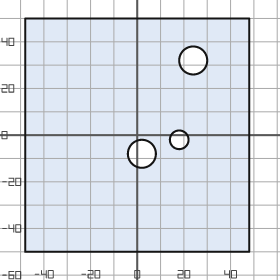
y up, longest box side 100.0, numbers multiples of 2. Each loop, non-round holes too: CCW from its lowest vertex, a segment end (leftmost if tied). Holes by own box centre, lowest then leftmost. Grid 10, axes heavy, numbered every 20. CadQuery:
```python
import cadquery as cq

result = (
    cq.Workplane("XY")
    .moveTo(-48.0, -50.0)
    .lineTo(48.0, -50.0)
    .lineTo(48.0, 50.0)
    .lineTo(-48.0, 50.0)
    .close()
    .moveTo(2.0, -8.0)
    .circle(6.0)
    .moveTo(18.0, -2.0)
    .circle(4.0)
    .moveTo(24.0, 32.0)
    .circle(6.0)
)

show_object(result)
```